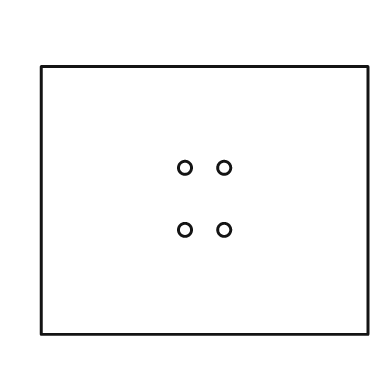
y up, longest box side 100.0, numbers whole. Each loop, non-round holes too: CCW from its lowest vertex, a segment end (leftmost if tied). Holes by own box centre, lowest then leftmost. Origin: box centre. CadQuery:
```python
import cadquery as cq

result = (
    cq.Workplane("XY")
    .moveTo(-50.0, -41.0)
    .lineTo(50.0, -41.0)
    .lineTo(50.0, 41.0)
    .lineTo(-50.0, 41.0)
    .close()
    .moveTo(-6.0, -9.0)
    .circle(2.0)
    .moveTo(6.0, -9.0)
    .circle(2.0)
    .moveTo(-6.0, 10.0)
    .circle(2.0)
    .moveTo(6.0, 10.0)
    .circle(2.0)
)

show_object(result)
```